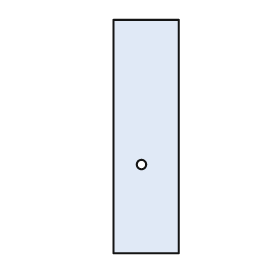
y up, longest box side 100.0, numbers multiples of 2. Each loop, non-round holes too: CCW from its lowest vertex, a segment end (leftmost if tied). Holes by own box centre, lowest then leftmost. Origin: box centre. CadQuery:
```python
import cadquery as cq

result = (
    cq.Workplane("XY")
    .moveTo(-14.0, -50.0)
    .lineTo(14.0, -50.0)
    .lineTo(14.0, 50.0)
    .lineTo(-14.0, 50.0)
    .close()
    .moveTo(-2.0, -12.0)
    .circle(2.0)
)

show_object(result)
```